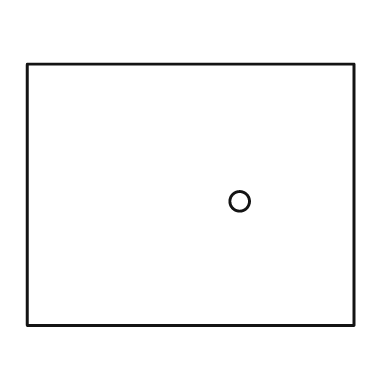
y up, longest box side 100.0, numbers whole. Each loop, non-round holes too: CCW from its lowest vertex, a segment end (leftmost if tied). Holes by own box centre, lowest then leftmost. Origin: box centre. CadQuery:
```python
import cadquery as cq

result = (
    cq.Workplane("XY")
    .moveTo(-50.0, -40.0)
    .lineTo(50.0, -40.0)
    .lineTo(50.0, 40.0)
    .lineTo(-50.0, 40.0)
    .close()
    .moveTo(15.0, -2.0)
    .circle(3.0)
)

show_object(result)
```